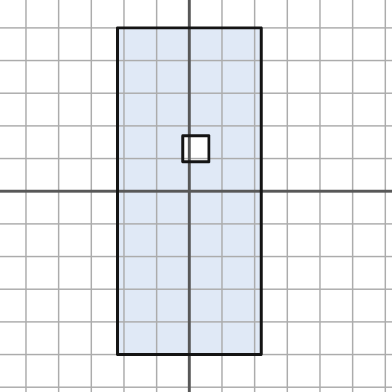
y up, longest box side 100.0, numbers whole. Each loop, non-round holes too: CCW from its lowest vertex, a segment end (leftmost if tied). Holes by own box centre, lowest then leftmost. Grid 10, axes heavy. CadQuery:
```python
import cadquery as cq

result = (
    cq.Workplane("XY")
    .moveTo(-22.0, -50.0)
    .lineTo(22.0, -50.0)
    .lineTo(22.0, 50.0)
    .lineTo(-22.0, 50.0)
    .close()
    .moveTo(-2.0, 9.0)
    .lineTo(6.0, 9.0)
    .lineTo(6.0, 17.0)
    .lineTo(-2.0, 17.0)
    .close()
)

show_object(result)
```